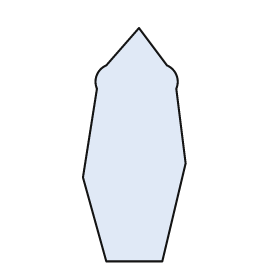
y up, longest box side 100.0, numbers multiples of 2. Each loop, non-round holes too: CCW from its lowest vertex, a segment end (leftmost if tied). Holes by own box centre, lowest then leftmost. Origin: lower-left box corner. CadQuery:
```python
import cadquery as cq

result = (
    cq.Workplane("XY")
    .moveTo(10.0, 0.0)
    .lineTo(34.0, 0.0)
    .lineTo(44.0, 42.0)
    .lineTo(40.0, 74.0)
    .threePointArc((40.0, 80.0), (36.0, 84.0))
    .lineTo(24.0, 100.0)
    .lineTo(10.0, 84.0)
    .threePointArc((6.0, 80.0), (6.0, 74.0))
    .lineTo(0.0, 36.0)
    .close()
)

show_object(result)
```